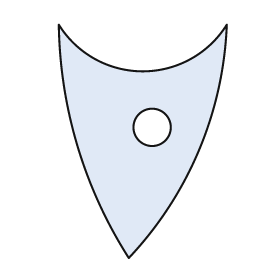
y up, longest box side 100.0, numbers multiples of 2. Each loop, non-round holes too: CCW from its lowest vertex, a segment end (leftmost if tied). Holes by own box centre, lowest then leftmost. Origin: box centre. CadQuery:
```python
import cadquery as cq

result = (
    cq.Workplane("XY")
    .moveTo(-6.0, -50.0)
    .threePointArc((24.0, -4.0), (36.0, 50.0))
    .threePointArc((0.0, 30.0), (-36.0, 50.0))
    .threePointArc((-28.0, -2.0), (-6.0, -50.0))
    .close()
    .moveTo(4.0, 6.0)
    .circle(8.0)
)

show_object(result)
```